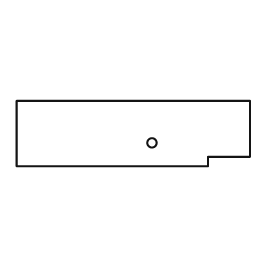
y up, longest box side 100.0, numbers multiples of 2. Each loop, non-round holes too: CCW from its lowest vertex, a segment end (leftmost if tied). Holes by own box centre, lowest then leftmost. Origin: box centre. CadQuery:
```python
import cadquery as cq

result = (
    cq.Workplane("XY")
    .moveTo(-50.0, -14.0)
    .lineTo(32.0, -14.0)
    .lineTo(32.0, -10.0)
    .lineTo(50.0, -10.0)
    .lineTo(50.0, 14.0)
    .lineTo(-50.0, 14.0)
    .close()
    .moveTo(8.0, -4.0)
    .circle(2.0)
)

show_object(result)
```